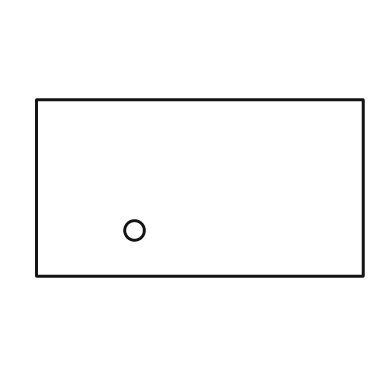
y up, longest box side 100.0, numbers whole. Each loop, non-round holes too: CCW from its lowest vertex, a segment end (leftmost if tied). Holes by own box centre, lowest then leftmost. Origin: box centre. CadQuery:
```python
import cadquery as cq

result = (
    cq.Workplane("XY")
    .moveTo(-50.0, -27.0)
    .lineTo(50.0, -27.0)
    .lineTo(50.0, 27.0)
    .lineTo(-50.0, 27.0)
    .close()
    .moveTo(-20.0, -13.0)
    .circle(3.0)
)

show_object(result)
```